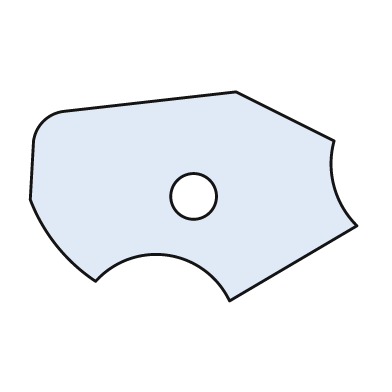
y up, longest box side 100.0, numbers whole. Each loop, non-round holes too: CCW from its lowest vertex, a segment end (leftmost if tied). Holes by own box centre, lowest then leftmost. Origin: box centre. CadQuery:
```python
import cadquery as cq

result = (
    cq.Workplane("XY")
    .moveTo(11.0, -32.0)
    .lineTo(50.0, -9.0)
    .threePointArc((43.0, 3.0), (43.0, 17.0))
    .lineTo(13.0, 32.0)
    .lineTo(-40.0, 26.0)
    .threePointArc((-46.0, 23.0), (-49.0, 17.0))
    .lineTo(-50.0, -1.0)
    .threePointArc((-42.0, -15.0), (-30.0, -26.0))
    .threePointArc((-8.0, -18.0), (11.0, -32.0))
    .close()
    .moveTo(0.0, 0.0)
    .circle(7.0)
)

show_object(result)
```